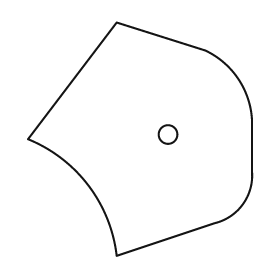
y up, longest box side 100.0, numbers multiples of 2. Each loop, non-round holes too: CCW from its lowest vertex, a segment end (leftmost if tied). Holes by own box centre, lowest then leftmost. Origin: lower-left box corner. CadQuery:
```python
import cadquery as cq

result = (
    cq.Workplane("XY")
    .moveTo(38.0, 0.0)
    .lineTo(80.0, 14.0)
    .threePointArc((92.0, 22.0), (96.0, 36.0))
    .lineTo(96.0, 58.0)
    .threePointArc((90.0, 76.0), (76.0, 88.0))
    .lineTo(38.0, 100.0)
    .lineTo(0.0, 50.0)
    .threePointArc((26.0, 30.0), (38.0, 0.0))
    .close()
    .moveTo(60.0, 52.0)
    .circle(4.0)
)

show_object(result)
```